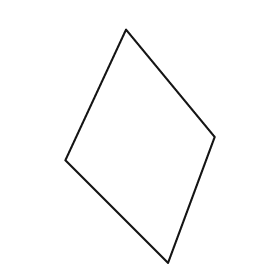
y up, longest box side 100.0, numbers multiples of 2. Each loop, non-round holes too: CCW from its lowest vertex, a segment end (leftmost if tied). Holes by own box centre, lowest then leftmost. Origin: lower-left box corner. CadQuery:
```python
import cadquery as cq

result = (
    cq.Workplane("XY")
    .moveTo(44.0, 0.0)
    .lineTo(64.0, 54.0)
    .lineTo(26.0, 100.0)
    .lineTo(0.0, 44.0)
    .close()
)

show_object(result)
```